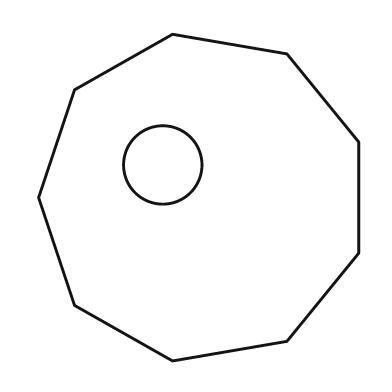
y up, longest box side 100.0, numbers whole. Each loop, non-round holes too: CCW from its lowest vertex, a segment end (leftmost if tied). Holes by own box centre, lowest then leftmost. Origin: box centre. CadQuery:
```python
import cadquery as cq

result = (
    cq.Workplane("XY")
    .moveTo(-8.0, -50.0)
    .lineTo(27.0, -44.0)
    .lineTo(49.0, -17.0)
    .lineTo(49.0, 17.0)
    .lineTo(27.0, 44.0)
    .lineTo(-8.0, 50.0)
    .lineTo(-38.0, 33.0)
    .lineTo(-49.0, 0.0)
    .lineTo(-38.0, -33.0)
    .close()
    .moveTo(-11.0, 10.0)
    .circle(12.0)
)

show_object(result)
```